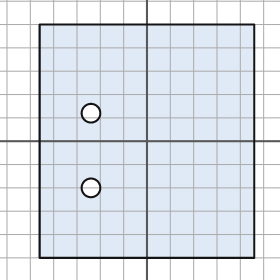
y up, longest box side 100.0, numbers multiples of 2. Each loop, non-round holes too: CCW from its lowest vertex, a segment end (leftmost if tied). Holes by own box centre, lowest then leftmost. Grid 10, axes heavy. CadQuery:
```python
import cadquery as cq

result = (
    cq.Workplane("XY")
    .moveTo(-46.0, -50.0)
    .lineTo(46.0, -50.0)
    .lineTo(46.0, 50.0)
    .lineTo(-46.0, 50.0)
    .close()
    .moveTo(-24.0, -20.0)
    .circle(4.0)
    .moveTo(-24.0, 12.0)
    .circle(4.0)
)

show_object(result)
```